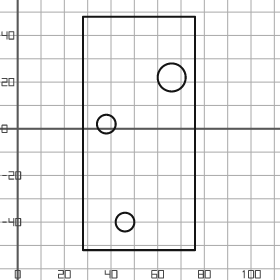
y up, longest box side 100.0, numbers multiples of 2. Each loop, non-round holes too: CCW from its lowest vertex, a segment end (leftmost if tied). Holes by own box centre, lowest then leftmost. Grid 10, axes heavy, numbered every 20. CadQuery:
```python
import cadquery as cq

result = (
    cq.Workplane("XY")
    .moveTo(28.0, -52.0)
    .lineTo(76.0, -52.0)
    .lineTo(76.0, 48.0)
    .lineTo(28.0, 48.0)
    .close()
    .moveTo(46.0, -40.0)
    .circle(4.0)
    .moveTo(38.0, 2.0)
    .circle(4.0)
    .moveTo(66.0, 22.0)
    .circle(6.0)
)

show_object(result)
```